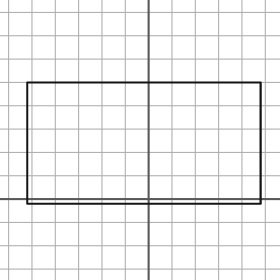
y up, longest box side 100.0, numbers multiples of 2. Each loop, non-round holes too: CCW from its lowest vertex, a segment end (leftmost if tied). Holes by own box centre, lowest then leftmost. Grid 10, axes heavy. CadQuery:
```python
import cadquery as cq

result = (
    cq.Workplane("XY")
    .moveTo(-52.0, -2.0)
    .lineTo(48.0, -2.0)
    .lineTo(48.0, 50.0)
    .lineTo(-52.0, 50.0)
    .close()
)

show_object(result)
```